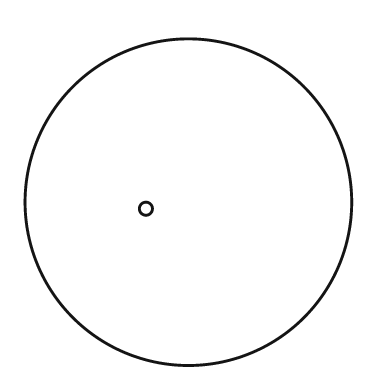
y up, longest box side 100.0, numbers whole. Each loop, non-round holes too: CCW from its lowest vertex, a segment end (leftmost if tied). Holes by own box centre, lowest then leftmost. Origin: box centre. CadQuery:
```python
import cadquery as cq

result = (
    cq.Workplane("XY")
    .moveTo(0.0, 0.0)
    .circle(50.0)
    .moveTo(-13.0, -2.0)
    .circle(2.0)
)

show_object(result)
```